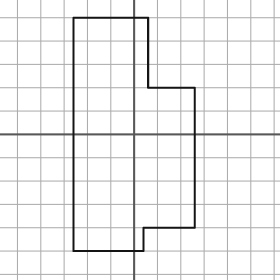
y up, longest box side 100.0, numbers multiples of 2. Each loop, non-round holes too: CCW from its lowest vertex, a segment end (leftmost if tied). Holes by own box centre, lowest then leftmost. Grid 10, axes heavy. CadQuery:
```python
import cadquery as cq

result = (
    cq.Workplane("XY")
    .moveTo(-26.0, -50.0)
    .lineTo(4.0, -50.0)
    .lineTo(4.0, -40.0)
    .lineTo(26.0, -40.0)
    .lineTo(26.0, 20.0)
    .lineTo(6.0, 20.0)
    .lineTo(6.0, 50.0)
    .lineTo(-26.0, 50.0)
    .close()
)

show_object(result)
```